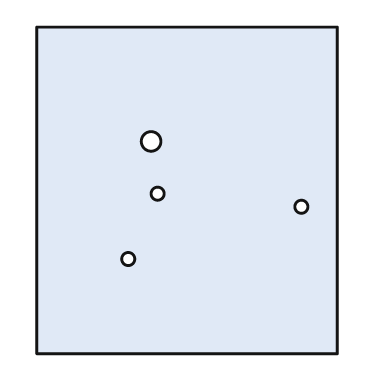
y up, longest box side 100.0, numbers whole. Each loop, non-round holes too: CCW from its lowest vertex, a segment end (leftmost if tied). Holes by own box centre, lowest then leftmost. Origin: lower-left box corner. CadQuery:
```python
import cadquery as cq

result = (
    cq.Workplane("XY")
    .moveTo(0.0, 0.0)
    .lineTo(92.0, 0.0)
    .lineTo(92.0, 100.0)
    .lineTo(0.0, 100.0)
    .close()
    .moveTo(28.0, 29.0)
    .circle(2.0)
    .moveTo(81.0, 45.0)
    .circle(2.0)
    .moveTo(37.0, 49.0)
    .circle(2.0)
    .moveTo(35.0, 65.0)
    .circle(3.0)
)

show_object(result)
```